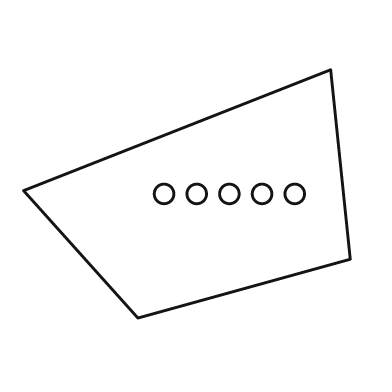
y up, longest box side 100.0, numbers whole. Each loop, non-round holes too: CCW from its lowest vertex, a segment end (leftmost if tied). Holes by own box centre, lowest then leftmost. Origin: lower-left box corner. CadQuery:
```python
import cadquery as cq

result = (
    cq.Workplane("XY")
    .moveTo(35.0, 0.0)
    .lineTo(100.0, 18.0)
    .lineTo(94.0, 76.0)
    .lineTo(0.0, 39.0)
    .close()
    .moveTo(43.0, 38.0)
    .circle(3.0)
    .moveTo(53.0, 38.0)
    .circle(3.0)
    .moveTo(63.0, 38.0)
    .circle(3.0)
    .moveTo(73.0, 38.0)
    .circle(3.0)
    .moveTo(83.0, 38.0)
    .circle(3.0)
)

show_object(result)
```